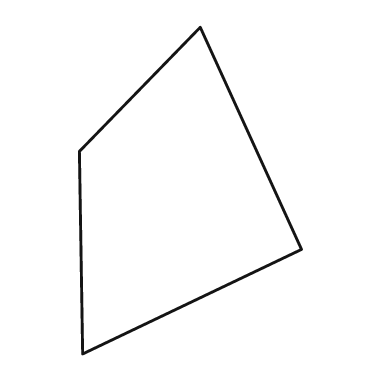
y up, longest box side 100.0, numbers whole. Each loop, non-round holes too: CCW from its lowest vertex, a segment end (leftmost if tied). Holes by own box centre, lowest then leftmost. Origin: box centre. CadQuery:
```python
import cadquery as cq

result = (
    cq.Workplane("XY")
    .moveTo(-33.0, -50.0)
    .lineTo(34.0, -18.0)
    .lineTo(3.0, 50.0)
    .lineTo(-34.0, 12.0)
    .close()
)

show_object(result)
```